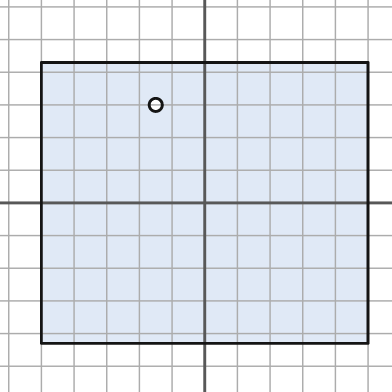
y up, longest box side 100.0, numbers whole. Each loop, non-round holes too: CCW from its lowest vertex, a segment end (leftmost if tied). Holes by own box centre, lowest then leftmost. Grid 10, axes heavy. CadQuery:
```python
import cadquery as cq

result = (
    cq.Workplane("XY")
    .moveTo(-50.0, -43.0)
    .lineTo(50.0, -43.0)
    .lineTo(50.0, 43.0)
    .lineTo(-50.0, 43.0)
    .close()
    .moveTo(-15.0, 30.0)
    .circle(2.0)
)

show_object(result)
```